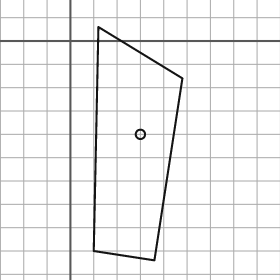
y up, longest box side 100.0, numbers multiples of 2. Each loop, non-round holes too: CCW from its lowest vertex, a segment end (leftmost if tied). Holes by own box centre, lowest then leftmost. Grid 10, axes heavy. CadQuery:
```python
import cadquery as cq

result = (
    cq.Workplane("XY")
    .moveTo(36.0, -94.0)
    .lineTo(48.0, -16.0)
    .lineTo(12.0, 6.0)
    .lineTo(10.0, -90.0)
    .close()
    .moveTo(30.0, -40.0)
    .circle(2.0)
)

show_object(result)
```